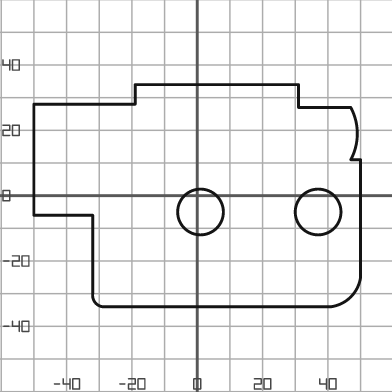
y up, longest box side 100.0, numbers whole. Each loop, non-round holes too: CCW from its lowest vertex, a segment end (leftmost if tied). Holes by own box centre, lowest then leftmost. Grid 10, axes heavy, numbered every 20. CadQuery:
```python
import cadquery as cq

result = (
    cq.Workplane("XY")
    .moveTo(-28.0, -34.0)
    .lineTo(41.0, -34.0)
    .threePointArc((47.0, -31.0), (50.0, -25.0))
    .lineTo(50.0, 11.0)
    .lineTo(47.0, 11.0)
    .threePointArc((49.0, 19.0), (47.0, 27.0))
    .lineTo(31.0, 27.0)
    .lineTo(31.0, 34.0)
    .lineTo(-19.0, 34.0)
    .lineTo(-19.0, 28.0)
    .lineTo(-50.0, 28.0)
    .lineTo(-50.0, -6.0)
    .lineTo(-32.0, -6.0)
    .lineTo(-32.0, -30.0)
    .threePointArc((-31.0, -33.0), (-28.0, -34.0))
    .close()
    .moveTo(1.0, -5.0)
    .circle(7.0)
    .moveTo(37.0, -5.0)
    .circle(7.0)
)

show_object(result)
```